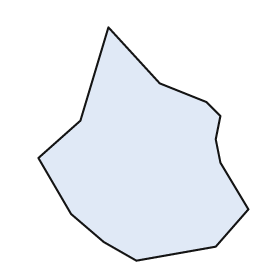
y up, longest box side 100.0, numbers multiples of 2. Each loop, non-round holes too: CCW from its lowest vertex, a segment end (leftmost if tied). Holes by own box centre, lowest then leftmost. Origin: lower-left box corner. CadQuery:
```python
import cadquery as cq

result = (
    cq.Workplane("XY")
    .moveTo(42.0, 0.0)
    .lineTo(76.0, 6.0)
    .lineTo(90.0, 22.0)
    .lineTo(78.0, 42.0)
    .lineTo(76.0, 52.0)
    .lineTo(78.0, 62.0)
    .lineTo(72.0, 68.0)
    .lineTo(52.0, 76.0)
    .lineTo(30.0, 100.0)
    .lineTo(18.0, 60.0)
    .lineTo(0.0, 44.0)
    .lineTo(14.0, 20.0)
    .lineTo(28.0, 8.0)
    .close()
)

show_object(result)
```